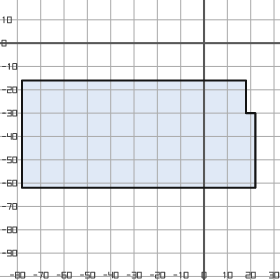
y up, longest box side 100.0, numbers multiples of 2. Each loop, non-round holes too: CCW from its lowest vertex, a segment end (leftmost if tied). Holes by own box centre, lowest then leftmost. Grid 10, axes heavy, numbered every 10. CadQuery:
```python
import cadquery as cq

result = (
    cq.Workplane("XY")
    .moveTo(-78.0, -62.0)
    .lineTo(22.0, -62.0)
    .lineTo(22.0, -30.0)
    .lineTo(18.0, -30.0)
    .lineTo(18.0, -16.0)
    .lineTo(-78.0, -16.0)
    .close()
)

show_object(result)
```